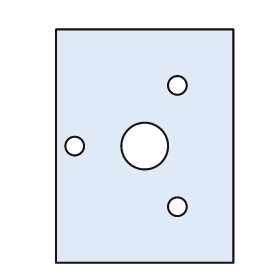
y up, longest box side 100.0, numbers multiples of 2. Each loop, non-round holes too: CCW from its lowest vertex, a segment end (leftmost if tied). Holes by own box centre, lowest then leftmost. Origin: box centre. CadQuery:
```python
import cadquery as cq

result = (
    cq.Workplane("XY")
    .moveTo(-38.0, -50.0)
    .lineTo(38.0, -50.0)
    .lineTo(38.0, 50.0)
    .lineTo(-38.0, 50.0)
    .close()
    .moveTo(14.0, -26.0)
    .circle(4.0)
    .moveTo(-30.0, 0.0)
    .circle(4.0)
    .moveTo(0.0, 0.0)
    .circle(10.0)
    .moveTo(14.0, 26.0)
    .circle(4.0)
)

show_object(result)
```